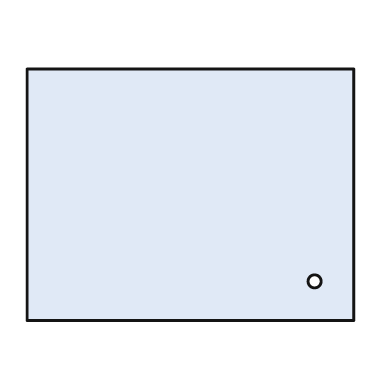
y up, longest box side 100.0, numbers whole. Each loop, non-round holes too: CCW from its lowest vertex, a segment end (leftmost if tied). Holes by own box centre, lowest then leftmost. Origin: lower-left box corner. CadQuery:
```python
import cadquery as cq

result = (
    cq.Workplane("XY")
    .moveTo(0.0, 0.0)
    .lineTo(100.0, 0.0)
    .lineTo(100.0, 77.0)
    .lineTo(0.0, 77.0)
    .close()
    .moveTo(88.0, 12.0)
    .circle(2.0)
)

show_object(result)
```